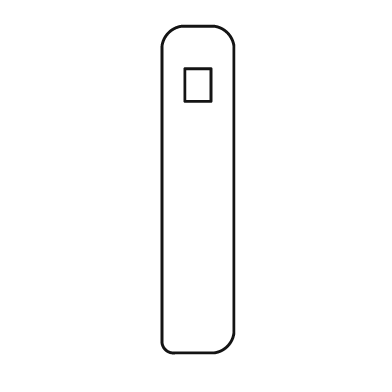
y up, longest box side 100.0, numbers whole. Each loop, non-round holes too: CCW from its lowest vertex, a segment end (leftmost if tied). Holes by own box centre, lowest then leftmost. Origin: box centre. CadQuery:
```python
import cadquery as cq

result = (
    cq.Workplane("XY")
    .moveTo(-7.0, -50.0)
    .lineTo(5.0, -50.0)
    .threePointArc((9.0, -48.0), (11.0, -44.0))
    .lineTo(11.0, 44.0)
    .threePointArc((9.0, 48.0), (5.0, 50.0))
    .lineTo(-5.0, 50.0)
    .threePointArc((-9.0, 48.0), (-11.0, 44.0))
    .lineTo(-11.0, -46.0)
    .threePointArc((-10.0, -49.0), (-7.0, -50.0))
    .close()
    .moveTo(-4.0, 27.0)
    .lineTo(4.0, 27.0)
    .lineTo(4.0, 37.0)
    .lineTo(-4.0, 37.0)
    .close()
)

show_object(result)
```